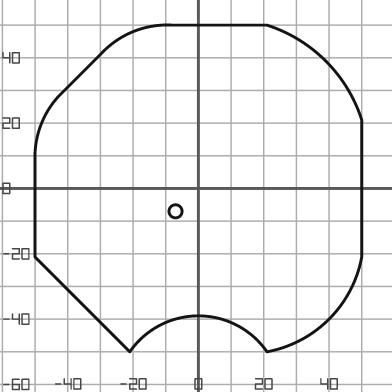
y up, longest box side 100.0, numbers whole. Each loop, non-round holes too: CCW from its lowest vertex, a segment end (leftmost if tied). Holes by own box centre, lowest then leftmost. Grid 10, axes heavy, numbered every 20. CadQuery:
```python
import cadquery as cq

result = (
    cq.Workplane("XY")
    .moveTo(-21.0, -50.0)
    .threePointArc((0.0, -39.0), (21.0, -50.0))
    .threePointArc((40.0, -40.0), (50.0, -21.0))
    .lineTo(50.0, 21.0)
    .threePointArc((39.0, 39.0), (21.0, 50.0))
    .lineTo(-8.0, 50.0)
    .threePointArc((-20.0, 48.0), (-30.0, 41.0))
    .lineTo(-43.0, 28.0)
    .threePointArc((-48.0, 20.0), (-50.0, 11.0))
    .lineTo(-50.0, -21.0)
    .close()
    .moveTo(-7.0, -7.0)
    .circle(2.0)
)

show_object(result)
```